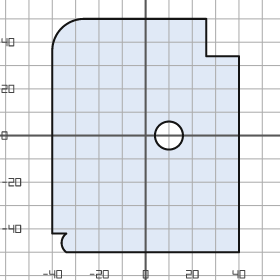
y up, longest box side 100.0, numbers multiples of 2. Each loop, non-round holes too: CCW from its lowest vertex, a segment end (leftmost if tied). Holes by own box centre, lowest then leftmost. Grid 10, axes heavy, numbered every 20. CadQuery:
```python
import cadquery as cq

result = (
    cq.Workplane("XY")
    .moveTo(-34.0, -50.0)
    .lineTo(40.0, -50.0)
    .lineTo(40.0, 34.0)
    .lineTo(26.0, 34.0)
    .lineTo(26.0, 50.0)
    .lineTo(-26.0, 50.0)
    .threePointArc((-36.0, 46.0), (-40.0, 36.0))
    .lineTo(-40.0, -42.0)
    .lineTo(-34.0, -42.0)
    .threePointArc((-36.0, -46.0), (-34.0, -50.0))
    .close()
    .moveTo(10.0, 0.0)
    .circle(6.0)
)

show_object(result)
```